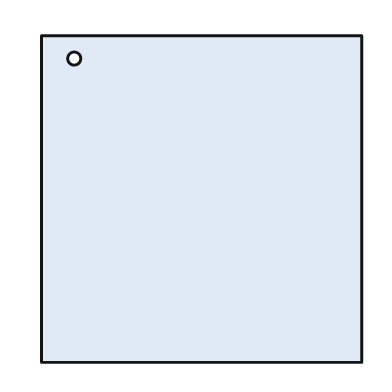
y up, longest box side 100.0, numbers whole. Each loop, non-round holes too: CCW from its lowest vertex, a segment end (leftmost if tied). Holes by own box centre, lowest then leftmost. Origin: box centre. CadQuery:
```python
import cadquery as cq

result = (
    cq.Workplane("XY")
    .moveTo(-49.0, -50.0)
    .lineTo(49.0, -50.0)
    .lineTo(49.0, 50.0)
    .lineTo(-49.0, 50.0)
    .close()
    .moveTo(-39.0, 43.0)
    .circle(2.0)
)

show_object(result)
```